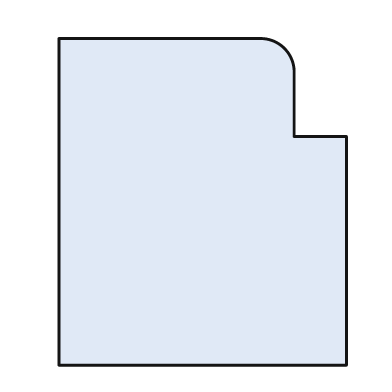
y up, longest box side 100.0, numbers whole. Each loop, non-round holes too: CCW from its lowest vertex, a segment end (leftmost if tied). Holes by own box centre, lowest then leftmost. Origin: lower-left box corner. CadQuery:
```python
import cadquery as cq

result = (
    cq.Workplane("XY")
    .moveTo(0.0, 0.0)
    .lineTo(88.0, 0.0)
    .lineTo(88.0, 70.0)
    .lineTo(72.0, 70.0)
    .lineTo(72.0, 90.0)
    .threePointArc((69.0, 97.0), (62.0, 100.0))
    .lineTo(0.0, 100.0)
    .close()
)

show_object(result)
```